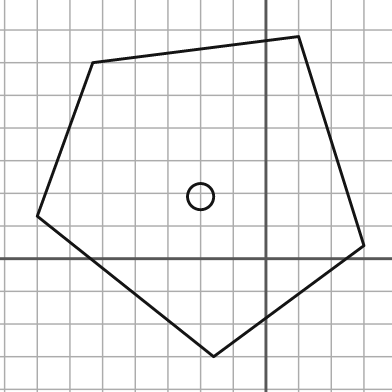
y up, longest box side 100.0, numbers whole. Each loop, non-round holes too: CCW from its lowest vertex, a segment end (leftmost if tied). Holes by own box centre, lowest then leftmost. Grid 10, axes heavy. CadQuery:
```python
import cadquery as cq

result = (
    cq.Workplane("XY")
    .moveTo(-16.0, -30.0)
    .lineTo(30.0, 4.0)
    .lineTo(10.0, 68.0)
    .lineTo(-53.0, 60.0)
    .lineTo(-70.0, 13.0)
    .close()
    .moveTo(-20.0, 19.0)
    .circle(4.0)
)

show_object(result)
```